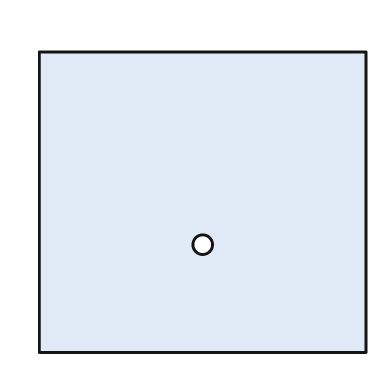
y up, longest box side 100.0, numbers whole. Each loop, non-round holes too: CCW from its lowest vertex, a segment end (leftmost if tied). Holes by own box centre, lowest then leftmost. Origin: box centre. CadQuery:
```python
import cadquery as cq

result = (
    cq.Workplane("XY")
    .moveTo(-50.0, -46.0)
    .lineTo(50.0, -46.0)
    .lineTo(50.0, 46.0)
    .lineTo(-50.0, 46.0)
    .close()
    .moveTo(0.0, -13.0)
    .circle(3.0)
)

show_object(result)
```